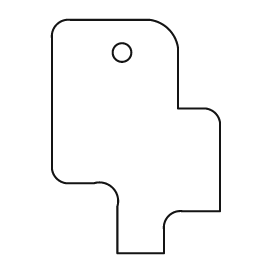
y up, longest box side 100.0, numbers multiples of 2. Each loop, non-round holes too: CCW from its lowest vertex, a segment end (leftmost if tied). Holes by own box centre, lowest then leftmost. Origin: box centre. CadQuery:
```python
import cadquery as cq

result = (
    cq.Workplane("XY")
    .moveTo(-8.0, -50.0)
    .lineTo(12.0, -50.0)
    .lineTo(12.0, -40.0)
    .threePointArc((14.0, -34.0), (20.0, -32.0))
    .lineTo(36.0, -32.0)
    .lineTo(36.0, 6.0)
    .threePointArc((34.0, 10.0), (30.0, 12.0))
    .lineTo(18.0, 12.0)
    .lineTo(18.0, 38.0)
    .threePointArc((14.0, 46.0), (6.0, 50.0))
    .lineTo(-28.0, 50.0)
    .threePointArc((-34.0, 48.0), (-36.0, 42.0))
    .lineTo(-36.0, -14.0)
    .threePointArc((-34.0, -18.0), (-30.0, -20.0))
    .lineTo(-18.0, -20.0)
    .threePointArc((-10.0, -22.0), (-8.0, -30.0))
    .close()
    .moveTo(-6.0, 36.0)
    .circle(4.0)
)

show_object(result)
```